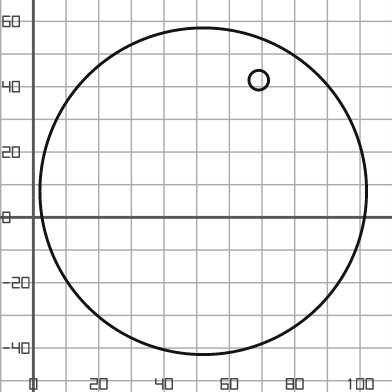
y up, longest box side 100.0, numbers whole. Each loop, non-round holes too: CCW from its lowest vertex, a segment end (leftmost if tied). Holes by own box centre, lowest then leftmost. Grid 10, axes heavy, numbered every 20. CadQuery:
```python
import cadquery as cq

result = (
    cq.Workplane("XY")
    .moveTo(52.0, 8.0)
    .circle(50.0)
    .moveTo(69.0, 42.0)
    .circle(3.0)
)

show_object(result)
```